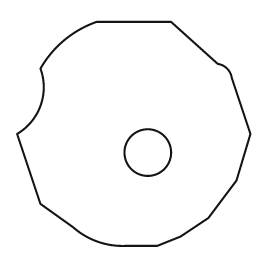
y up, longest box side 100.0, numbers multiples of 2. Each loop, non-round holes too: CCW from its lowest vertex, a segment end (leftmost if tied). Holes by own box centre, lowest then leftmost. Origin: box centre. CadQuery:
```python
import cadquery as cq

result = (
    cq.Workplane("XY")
    .moveTo(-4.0, -48.0)
    .lineTo(10.0, -48.0)
    .lineTo(20.0, -44.0)
    .lineTo(32.0, -36.0)
    .lineTo(44.0, -20.0)
    .lineTo(50.0, 0.0)
    .lineTo(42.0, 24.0)
    .threePointArc((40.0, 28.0), (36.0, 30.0))
    .lineTo(16.0, 48.0)
    .lineTo(-16.0, 48.0)
    .threePointArc((-30.0, 40.0), (-40.0, 28.0))
    .threePointArc((-40.0, 12.0), (-50.0, 0.0))
    .lineTo(-40.0, -30.0)
    .lineTo(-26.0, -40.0)
    .threePointArc((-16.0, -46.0), (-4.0, -48.0))
    .close()
    .moveTo(6.0, -8.0)
    .circle(10.0)
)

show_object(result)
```